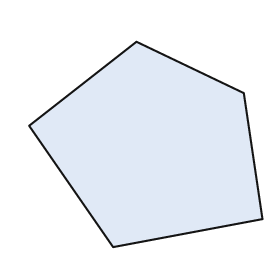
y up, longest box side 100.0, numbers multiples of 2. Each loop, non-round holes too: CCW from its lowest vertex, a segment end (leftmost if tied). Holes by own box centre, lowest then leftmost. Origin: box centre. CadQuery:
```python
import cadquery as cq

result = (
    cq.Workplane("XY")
    .moveTo(-14.0, -44.0)
    .lineTo(50.0, -32.0)
    .lineTo(42.0, 22.0)
    .lineTo(-4.0, 44.0)
    .lineTo(-50.0, 8.0)
    .close()
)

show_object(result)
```